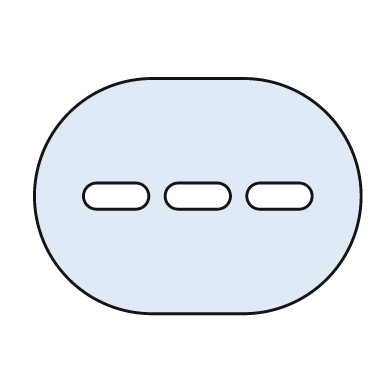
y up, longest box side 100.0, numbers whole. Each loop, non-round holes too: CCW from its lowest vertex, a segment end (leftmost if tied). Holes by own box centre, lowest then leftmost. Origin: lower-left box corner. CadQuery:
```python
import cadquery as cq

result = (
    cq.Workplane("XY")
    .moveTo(36.0, 0.0)
    .lineTo(64.0, 0.0)
    .threePointArc((100.0, 36.0), (64.0, 72.0))
    .lineTo(36.0, 72.0)
    .threePointArc((0.0, 36.0), (36.0, 0.0))
    .close()
    .moveTo(19.0, 32.0)
    .lineTo(31.0, 32.0)
    .threePointArc((35.0, 36.0), (31.0, 40.0))
    .lineTo(19.0, 40.0)
    .threePointArc((15.0, 36.0), (19.0, 32.0))
    .close()
    .moveTo(44.0, 32.0)
    .lineTo(56.0, 32.0)
    .threePointArc((60.0, 36.0), (56.0, 40.0))
    .lineTo(44.0, 40.0)
    .threePointArc((40.0, 36.0), (44.0, 32.0))
    .close()
    .moveTo(69.0, 32.0)
    .lineTo(81.0, 32.0)
    .threePointArc((85.0, 36.0), (81.0, 40.0))
    .lineTo(69.0, 40.0)
    .threePointArc((65.0, 36.0), (69.0, 32.0))
    .close()
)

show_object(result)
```